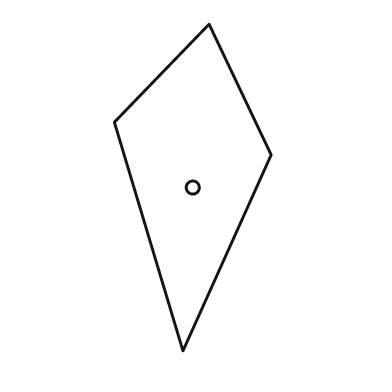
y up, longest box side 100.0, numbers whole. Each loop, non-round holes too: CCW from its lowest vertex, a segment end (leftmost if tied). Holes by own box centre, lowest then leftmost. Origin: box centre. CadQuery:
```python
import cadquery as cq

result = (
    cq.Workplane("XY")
    .moveTo(-3.0, -50.0)
    .lineTo(24.0, 10.0)
    .lineTo(5.0, 50.0)
    .lineTo(-24.0, 20.0)
    .close()
    .moveTo(0.0, 0.0)
    .circle(2.0)
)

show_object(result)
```